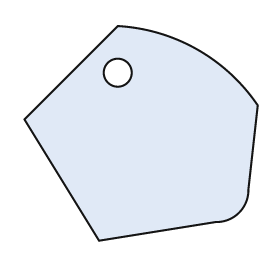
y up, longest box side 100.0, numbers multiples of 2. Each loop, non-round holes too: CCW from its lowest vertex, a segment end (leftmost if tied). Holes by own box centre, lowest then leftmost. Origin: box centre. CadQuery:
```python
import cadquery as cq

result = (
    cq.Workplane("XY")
    .moveTo(-18.0, -46.0)
    .lineTo(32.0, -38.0)
    .threePointArc((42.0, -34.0), (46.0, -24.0))
    .lineTo(50.0, 12.0)
    .threePointArc((24.0, 36.0), (-10.0, 46.0))
    .lineTo(-50.0, 6.0)
    .close()
    .moveTo(-10.0, 26.0)
    .circle(6.0)
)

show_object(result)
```